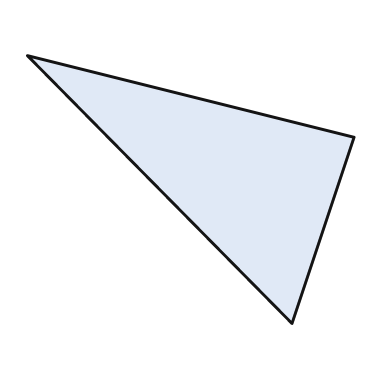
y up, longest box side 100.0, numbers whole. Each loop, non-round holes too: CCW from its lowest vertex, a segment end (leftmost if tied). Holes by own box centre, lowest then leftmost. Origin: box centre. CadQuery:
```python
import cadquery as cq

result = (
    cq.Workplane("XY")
    .moveTo(31.0, -41.0)
    .lineTo(50.0, 16.0)
    .lineTo(-50.0, 41.0)
    .close()
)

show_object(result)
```